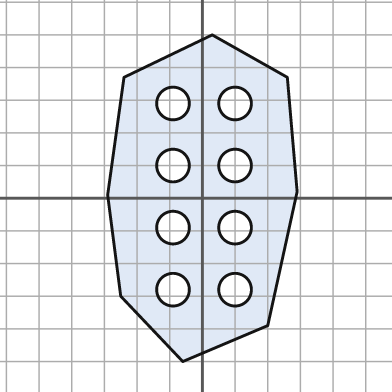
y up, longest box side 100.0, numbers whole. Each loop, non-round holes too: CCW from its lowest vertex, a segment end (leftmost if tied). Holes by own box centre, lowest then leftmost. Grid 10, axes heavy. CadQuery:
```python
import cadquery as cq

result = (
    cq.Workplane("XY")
    .moveTo(-6.0, -50.0)
    .lineTo(20.0, -39.0)
    .lineTo(29.0, 2.0)
    .lineTo(26.0, 37.0)
    .lineTo(3.0, 50.0)
    .lineTo(-24.0, 37.0)
    .lineTo(-29.0, 1.0)
    .lineTo(-25.0, -30.0)
    .close()
    .moveTo(-9.0, -28.0)
    .circle(5.0)
    .moveTo(10.0, -28.0)
    .circle(5.0)
    .moveTo(-9.0, -9.0)
    .circle(5.0)
    .moveTo(10.0, -9.0)
    .circle(5.0)
    .moveTo(-9.0, 10.0)
    .circle(5.0)
    .moveTo(10.0, 10.0)
    .circle(5.0)
    .moveTo(-9.0, 29.0)
    .circle(5.0)
    .moveTo(10.0, 29.0)
    .circle(5.0)
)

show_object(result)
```